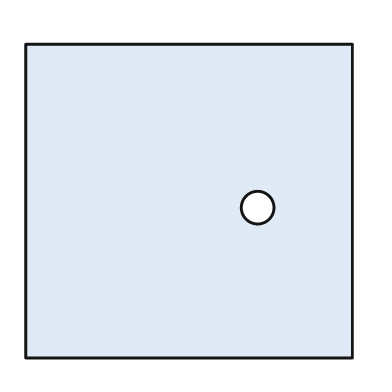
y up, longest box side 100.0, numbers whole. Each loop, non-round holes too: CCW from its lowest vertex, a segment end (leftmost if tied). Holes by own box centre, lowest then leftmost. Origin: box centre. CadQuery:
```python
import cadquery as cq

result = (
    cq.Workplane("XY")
    .moveTo(-50.0, -48.0)
    .lineTo(50.0, -48.0)
    .lineTo(50.0, 48.0)
    .lineTo(-50.0, 48.0)
    .close()
    .moveTo(21.0, -2.0)
    .circle(5.0)
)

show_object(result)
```